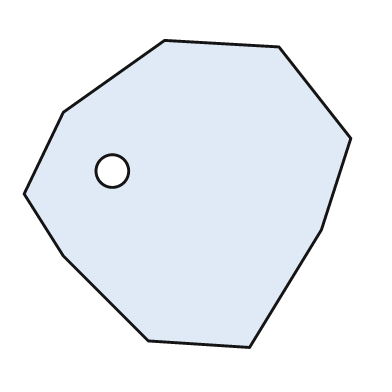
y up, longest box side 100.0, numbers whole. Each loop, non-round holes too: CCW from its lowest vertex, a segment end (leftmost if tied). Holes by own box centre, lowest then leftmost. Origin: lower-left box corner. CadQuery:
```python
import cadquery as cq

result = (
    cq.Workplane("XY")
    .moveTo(69.0, 0.0)
    .lineTo(91.0, 36.0)
    .lineTo(100.0, 64.0)
    .lineTo(78.0, 92.0)
    .lineTo(43.0, 94.0)
    .lineTo(12.0, 72.0)
    .lineTo(0.0, 47.0)
    .lineTo(12.0, 28.0)
    .lineTo(38.0, 2.0)
    .close()
    .moveTo(27.0, 54.0)
    .circle(5.0)
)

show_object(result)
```